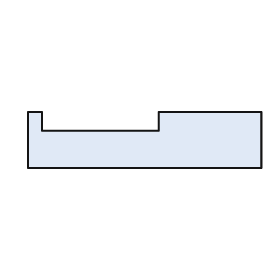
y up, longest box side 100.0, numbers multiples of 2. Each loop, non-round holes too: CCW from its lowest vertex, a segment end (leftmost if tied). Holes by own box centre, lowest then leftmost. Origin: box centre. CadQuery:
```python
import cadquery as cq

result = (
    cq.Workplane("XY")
    .moveTo(-50.0, -12.0)
    .lineTo(50.0, -12.0)
    .lineTo(50.0, 12.0)
    .lineTo(6.0, 12.0)
    .lineTo(6.0, 4.0)
    .lineTo(-44.0, 4.0)
    .lineTo(-44.0, 12.0)
    .lineTo(-50.0, 12.0)
    .close()
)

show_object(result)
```